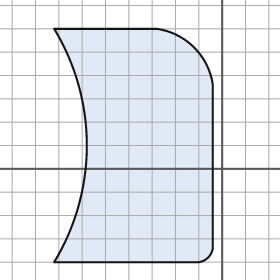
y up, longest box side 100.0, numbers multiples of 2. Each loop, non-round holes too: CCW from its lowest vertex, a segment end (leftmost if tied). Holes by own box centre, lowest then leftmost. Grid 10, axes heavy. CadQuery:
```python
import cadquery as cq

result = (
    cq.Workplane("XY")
    .moveTo(-72.0, -40.0)
    .lineTo(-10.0, -40.0)
    .threePointArc((-6.0, -38.0), (-4.0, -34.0))
    .lineTo(-4.0, 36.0)
    .threePointArc((-12.0, 52.0), (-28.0, 60.0))
    .lineTo(-72.0, 60.0)
    .threePointArc((-58.0, 10.0), (-72.0, -40.0))
    .close()
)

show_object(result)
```